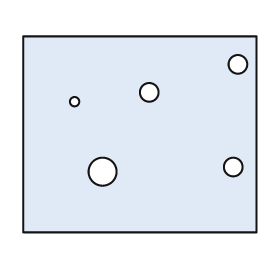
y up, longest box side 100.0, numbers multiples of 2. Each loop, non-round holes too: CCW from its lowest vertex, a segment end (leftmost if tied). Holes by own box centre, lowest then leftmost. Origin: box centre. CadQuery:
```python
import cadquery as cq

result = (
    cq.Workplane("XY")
    .moveTo(-50.0, -42.0)
    .lineTo(50.0, -42.0)
    .lineTo(50.0, 42.0)
    .lineTo(-50.0, 42.0)
    .close()
    .moveTo(-16.0, -16.0)
    .circle(6.0)
    .moveTo(40.0, -14.0)
    .circle(4.0)
    .moveTo(-28.0, 14.0)
    .circle(2.0)
    .moveTo(4.0, 18.0)
    .circle(4.0)
    .moveTo(42.0, 30.0)
    .circle(4.0)
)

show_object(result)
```